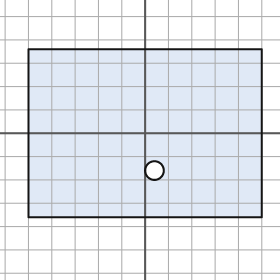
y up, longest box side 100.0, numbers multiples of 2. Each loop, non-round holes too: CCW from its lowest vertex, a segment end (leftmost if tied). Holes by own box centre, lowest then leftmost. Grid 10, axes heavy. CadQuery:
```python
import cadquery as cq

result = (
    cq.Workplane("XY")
    .moveTo(-50.0, -36.0)
    .lineTo(50.0, -36.0)
    .lineTo(50.0, 36.0)
    .lineTo(-50.0, 36.0)
    .close()
    .moveTo(4.0, -16.0)
    .circle(4.0)
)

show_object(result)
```